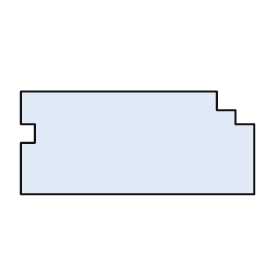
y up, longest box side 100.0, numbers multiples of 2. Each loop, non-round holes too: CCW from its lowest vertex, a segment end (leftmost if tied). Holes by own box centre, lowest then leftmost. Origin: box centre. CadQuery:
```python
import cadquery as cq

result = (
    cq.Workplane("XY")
    .moveTo(-50.0, -22.0)
    .lineTo(50.0, -22.0)
    .lineTo(50.0, 8.0)
    .lineTo(42.0, 8.0)
    .lineTo(42.0, 14.0)
    .lineTo(34.0, 14.0)
    .lineTo(34.0, 22.0)
    .lineTo(-50.0, 22.0)
    .lineTo(-50.0, 8.0)
    .lineTo(-44.0, 8.0)
    .lineTo(-44.0, 0.0)
    .lineTo(-50.0, 0.0)
    .close()
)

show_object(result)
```